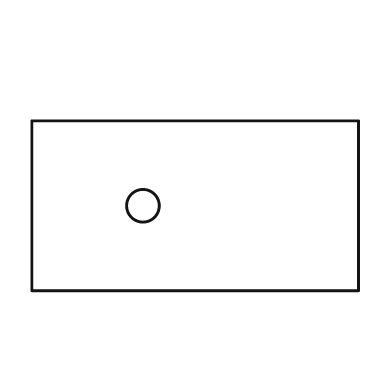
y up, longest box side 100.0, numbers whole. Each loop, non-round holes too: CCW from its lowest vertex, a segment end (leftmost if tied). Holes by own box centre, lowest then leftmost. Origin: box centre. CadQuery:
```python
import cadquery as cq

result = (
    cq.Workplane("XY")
    .moveTo(-50.0, -26.0)
    .lineTo(50.0, -26.0)
    .lineTo(50.0, 26.0)
    .lineTo(-50.0, 26.0)
    .close()
    .moveTo(-16.0, 0.0)
    .circle(5.0)
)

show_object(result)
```